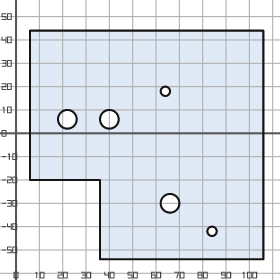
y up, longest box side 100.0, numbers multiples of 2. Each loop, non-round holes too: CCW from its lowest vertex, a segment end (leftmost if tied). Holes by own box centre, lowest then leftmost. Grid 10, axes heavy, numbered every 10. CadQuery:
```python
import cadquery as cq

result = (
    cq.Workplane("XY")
    .moveTo(36.0, -54.0)
    .lineTo(106.0, -54.0)
    .lineTo(106.0, 44.0)
    .lineTo(6.0, 44.0)
    .lineTo(6.0, -20.0)
    .lineTo(36.0, -20.0)
    .close()
    .moveTo(84.0, -42.0)
    .circle(2.0)
    .moveTo(66.0, -30.0)
    .circle(4.0)
    .moveTo(22.0, 6.0)
    .circle(4.0)
    .moveTo(40.0, 6.0)
    .circle(4.0)
    .moveTo(64.0, 18.0)
    .circle(2.0)
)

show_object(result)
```